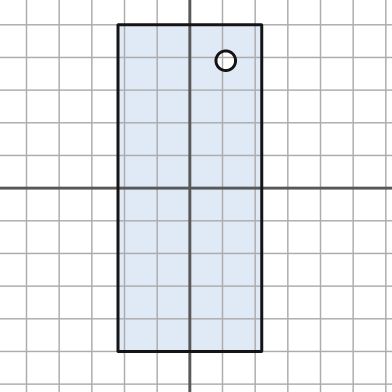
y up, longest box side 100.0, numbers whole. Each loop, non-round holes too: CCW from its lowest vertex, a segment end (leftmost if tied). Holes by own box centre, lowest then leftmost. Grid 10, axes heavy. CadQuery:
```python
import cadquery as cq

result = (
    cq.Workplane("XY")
    .moveTo(-22.0, -50.0)
    .lineTo(22.0, -50.0)
    .lineTo(22.0, 50.0)
    .lineTo(-22.0, 50.0)
    .close()
    .moveTo(11.0, 39.0)
    .circle(3.0)
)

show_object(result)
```